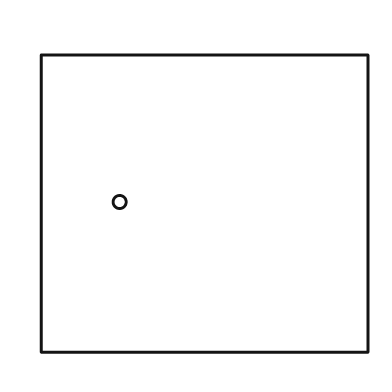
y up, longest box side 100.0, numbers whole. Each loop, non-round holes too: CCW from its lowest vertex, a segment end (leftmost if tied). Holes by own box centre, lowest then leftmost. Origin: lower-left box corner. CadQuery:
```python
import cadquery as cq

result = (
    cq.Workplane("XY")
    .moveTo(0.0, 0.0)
    .lineTo(100.0, 0.0)
    .lineTo(100.0, 91.0)
    .lineTo(0.0, 91.0)
    .close()
    .moveTo(24.0, 46.0)
    .circle(2.0)
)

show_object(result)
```